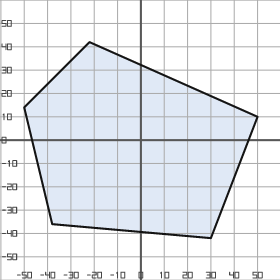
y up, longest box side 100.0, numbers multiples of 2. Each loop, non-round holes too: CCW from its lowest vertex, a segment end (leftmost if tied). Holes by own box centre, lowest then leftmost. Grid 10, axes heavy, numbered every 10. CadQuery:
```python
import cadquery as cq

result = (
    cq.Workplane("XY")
    .moveTo(30.0, -42.0)
    .lineTo(50.0, 10.0)
    .lineTo(-22.0, 42.0)
    .lineTo(-50.0, 14.0)
    .lineTo(-38.0, -36.0)
    .close()
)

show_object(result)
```